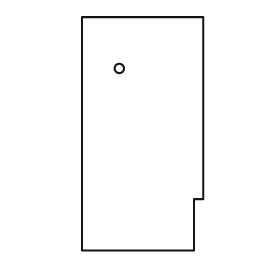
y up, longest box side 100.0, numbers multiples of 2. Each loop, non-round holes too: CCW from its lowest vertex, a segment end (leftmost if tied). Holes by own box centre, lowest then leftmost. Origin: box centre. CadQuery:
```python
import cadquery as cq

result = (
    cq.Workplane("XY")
    .moveTo(-26.0, -50.0)
    .lineTo(22.0, -50.0)
    .lineTo(22.0, -28.0)
    .lineTo(26.0, -28.0)
    .lineTo(26.0, 50.0)
    .lineTo(-26.0, 50.0)
    .close()
    .moveTo(-10.0, 28.0)
    .circle(2.0)
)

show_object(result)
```